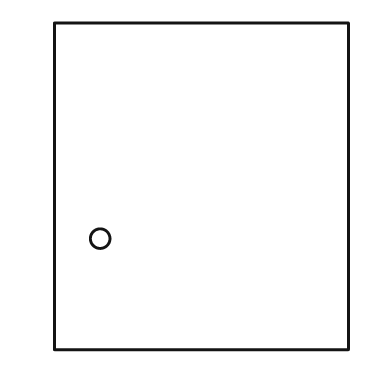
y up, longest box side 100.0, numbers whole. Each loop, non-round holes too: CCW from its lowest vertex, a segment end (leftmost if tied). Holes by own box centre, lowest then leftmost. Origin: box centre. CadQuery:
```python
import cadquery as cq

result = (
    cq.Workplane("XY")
    .moveTo(-45.0, -50.0)
    .lineTo(45.0, -50.0)
    .lineTo(45.0, 50.0)
    .lineTo(-45.0, 50.0)
    .close()
    .moveTo(-31.0, -16.0)
    .circle(3.0)
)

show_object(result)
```